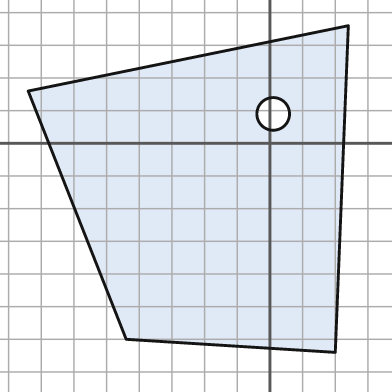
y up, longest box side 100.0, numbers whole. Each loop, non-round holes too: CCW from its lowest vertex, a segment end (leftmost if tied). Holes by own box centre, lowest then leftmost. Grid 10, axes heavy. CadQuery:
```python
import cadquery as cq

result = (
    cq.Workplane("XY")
    .moveTo(20.0, -64.0)
    .lineTo(24.0, 36.0)
    .lineTo(-74.0, 16.0)
    .lineTo(-44.0, -60.0)
    .close()
    .moveTo(1.0, 9.0)
    .circle(5.0)
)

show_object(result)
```